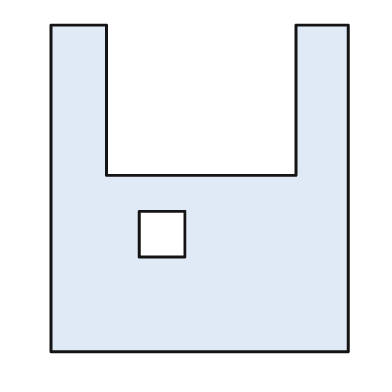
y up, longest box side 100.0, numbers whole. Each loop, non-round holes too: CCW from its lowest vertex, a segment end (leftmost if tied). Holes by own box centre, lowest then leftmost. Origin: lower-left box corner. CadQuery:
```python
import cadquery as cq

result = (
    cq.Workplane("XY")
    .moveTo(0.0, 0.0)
    .lineTo(91.0, 0.0)
    .lineTo(91.0, 100.0)
    .lineTo(75.0, 100.0)
    .lineTo(75.0, 54.0)
    .lineTo(17.0, 54.0)
    .lineTo(17.0, 100.0)
    .lineTo(0.0, 100.0)
    .close()
    .moveTo(27.0, 29.0)
    .lineTo(41.0, 29.0)
    .lineTo(41.0, 43.0)
    .lineTo(27.0, 43.0)
    .close()
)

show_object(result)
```